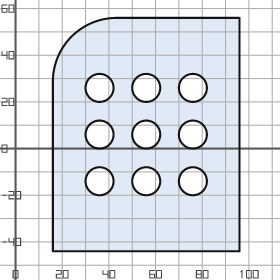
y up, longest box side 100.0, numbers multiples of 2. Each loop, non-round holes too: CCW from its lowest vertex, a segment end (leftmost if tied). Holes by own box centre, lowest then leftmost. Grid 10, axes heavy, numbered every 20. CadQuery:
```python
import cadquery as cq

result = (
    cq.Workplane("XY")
    .moveTo(16.0, -44.0)
    .lineTo(96.0, -44.0)
    .lineTo(96.0, 56.0)
    .lineTo(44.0, 56.0)
    .threePointArc((24.0, 48.0), (16.0, 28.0))
    .close()
    .moveTo(36.0, -14.0)
    .circle(6.0)
    .moveTo(56.0, -14.0)
    .circle(6.0)
    .moveTo(76.0, -14.0)
    .circle(6.0)
    .moveTo(36.0, 6.0)
    .circle(6.0)
    .moveTo(56.0, 6.0)
    .circle(6.0)
    .moveTo(76.0, 6.0)
    .circle(6.0)
    .moveTo(36.0, 26.0)
    .circle(6.0)
    .moveTo(56.0, 26.0)
    .circle(6.0)
    .moveTo(76.0, 26.0)
    .circle(6.0)
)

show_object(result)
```